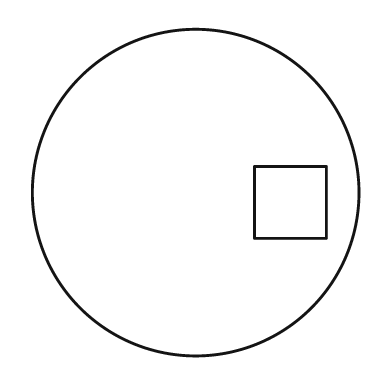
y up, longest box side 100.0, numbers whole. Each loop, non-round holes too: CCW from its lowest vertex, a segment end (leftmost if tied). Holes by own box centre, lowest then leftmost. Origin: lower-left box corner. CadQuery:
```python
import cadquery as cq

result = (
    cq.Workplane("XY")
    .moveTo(50.0, 50.0)
    .circle(50.0)
    .moveTo(68.0, 36.0)
    .lineTo(90.0, 36.0)
    .lineTo(90.0, 58.0)
    .lineTo(68.0, 58.0)
    .close()
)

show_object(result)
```